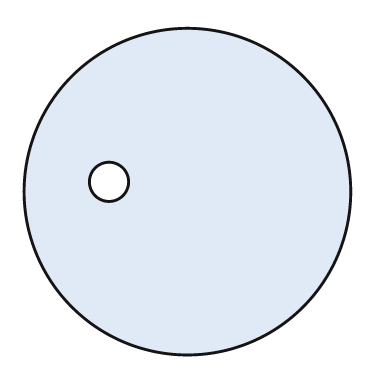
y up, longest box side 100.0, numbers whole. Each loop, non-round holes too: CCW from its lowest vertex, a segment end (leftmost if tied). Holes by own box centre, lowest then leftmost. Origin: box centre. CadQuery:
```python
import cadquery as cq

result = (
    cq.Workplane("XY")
    .moveTo(0.0, 0.0)
    .circle(50.0)
    .moveTo(-24.0, 3.0)
    .circle(6.0)
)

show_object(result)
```